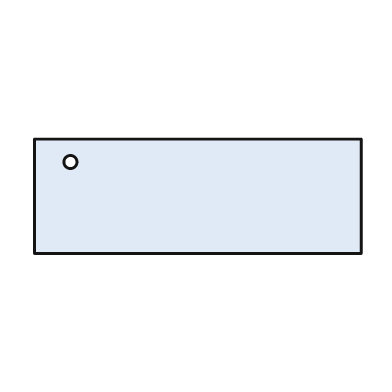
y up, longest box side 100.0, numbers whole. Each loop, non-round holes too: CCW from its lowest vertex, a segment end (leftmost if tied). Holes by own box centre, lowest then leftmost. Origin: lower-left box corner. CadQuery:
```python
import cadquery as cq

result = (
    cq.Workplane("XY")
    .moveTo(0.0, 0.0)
    .lineTo(100.0, 0.0)
    .lineTo(100.0, 35.0)
    .lineTo(0.0, 35.0)
    .close()
    .moveTo(11.0, 28.0)
    .circle(2.0)
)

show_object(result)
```